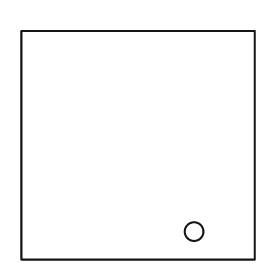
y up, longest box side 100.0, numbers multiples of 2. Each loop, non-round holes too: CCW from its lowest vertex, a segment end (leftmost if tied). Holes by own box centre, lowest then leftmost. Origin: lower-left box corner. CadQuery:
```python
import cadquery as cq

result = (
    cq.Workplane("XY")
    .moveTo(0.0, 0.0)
    .lineTo(100.0, 0.0)
    .lineTo(100.0, 98.0)
    .lineTo(0.0, 98.0)
    .close()
    .moveTo(74.0, 12.0)
    .circle(4.0)
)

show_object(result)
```